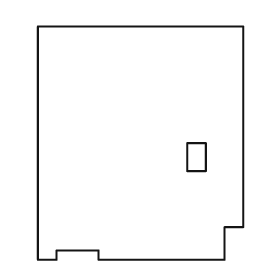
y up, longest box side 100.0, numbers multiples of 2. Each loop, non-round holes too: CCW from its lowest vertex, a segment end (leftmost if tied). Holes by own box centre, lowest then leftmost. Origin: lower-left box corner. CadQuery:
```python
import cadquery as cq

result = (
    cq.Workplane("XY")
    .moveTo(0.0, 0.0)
    .lineTo(8.0, 0.0)
    .lineTo(8.0, 4.0)
    .lineTo(26.0, 4.0)
    .lineTo(26.0, 0.0)
    .lineTo(80.0, 0.0)
    .lineTo(80.0, 14.0)
    .lineTo(88.0, 14.0)
    .lineTo(88.0, 100.0)
    .lineTo(0.0, 100.0)
    .close()
    .moveTo(64.0, 38.0)
    .lineTo(72.0, 38.0)
    .lineTo(72.0, 50.0)
    .lineTo(64.0, 50.0)
    .close()
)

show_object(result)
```